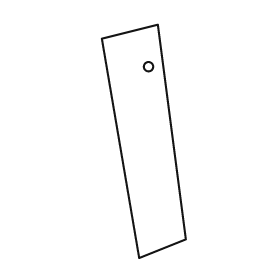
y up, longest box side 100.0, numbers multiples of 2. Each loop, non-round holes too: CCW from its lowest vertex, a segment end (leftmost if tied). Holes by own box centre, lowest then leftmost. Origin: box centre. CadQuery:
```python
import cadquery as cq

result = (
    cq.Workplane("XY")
    .moveTo(-2.0, -50.0)
    .lineTo(18.0, -42.0)
    .lineTo(6.0, 50.0)
    .lineTo(-18.0, 44.0)
    .close()
    .moveTo(2.0, 32.0)
    .circle(2.0)
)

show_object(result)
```